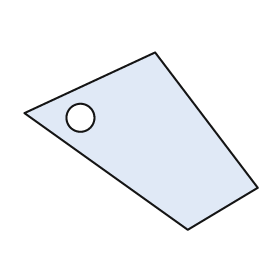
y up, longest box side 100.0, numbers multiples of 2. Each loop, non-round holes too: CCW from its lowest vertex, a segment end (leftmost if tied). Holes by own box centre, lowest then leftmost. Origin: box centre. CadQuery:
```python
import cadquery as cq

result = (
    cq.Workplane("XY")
    .moveTo(20.0, -38.0)
    .lineTo(50.0, -20.0)
    .lineTo(6.0, 38.0)
    .lineTo(-50.0, 12.0)
    .close()
    .moveTo(-26.0, 10.0)
    .circle(6.0)
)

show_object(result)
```